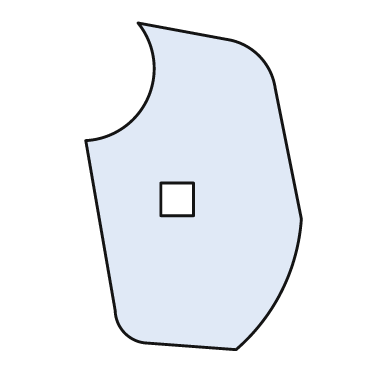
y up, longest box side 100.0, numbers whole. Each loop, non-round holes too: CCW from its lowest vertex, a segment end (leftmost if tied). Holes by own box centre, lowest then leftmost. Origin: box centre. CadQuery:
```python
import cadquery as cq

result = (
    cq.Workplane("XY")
    .moveTo(13.0, -50.0)
    .threePointArc((27.0, -32.0), (33.0, -10.0))
    .lineTo(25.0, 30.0)
    .threePointArc((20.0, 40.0), (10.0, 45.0))
    .lineTo(-17.0, 50.0)
    .threePointArc((-14.0, 27.0), (-33.0, 14.0))
    .lineTo(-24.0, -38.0)
    .threePointArc((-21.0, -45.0), (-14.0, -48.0))
    .close()
    .moveTo(-10.0, -9.0)
    .lineTo(0.0, -9.0)
    .lineTo(0.0, 1.0)
    .lineTo(-10.0, 1.0)
    .close()
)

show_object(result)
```